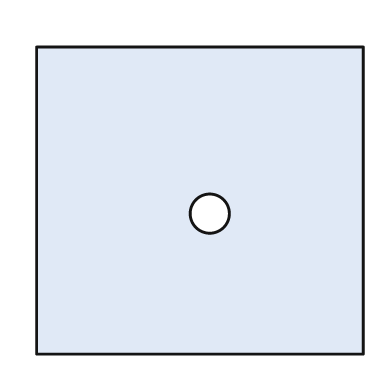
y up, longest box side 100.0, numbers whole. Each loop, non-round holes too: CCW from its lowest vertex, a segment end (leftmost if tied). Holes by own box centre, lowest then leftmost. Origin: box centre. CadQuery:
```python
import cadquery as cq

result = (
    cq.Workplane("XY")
    .moveTo(-50.0, -47.0)
    .lineTo(50.0, -47.0)
    .lineTo(50.0, 47.0)
    .lineTo(-50.0, 47.0)
    .close()
    .moveTo(3.0, -4.0)
    .circle(6.0)
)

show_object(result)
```